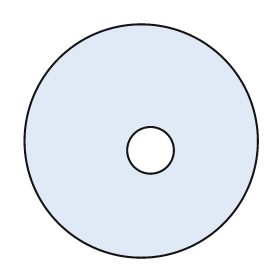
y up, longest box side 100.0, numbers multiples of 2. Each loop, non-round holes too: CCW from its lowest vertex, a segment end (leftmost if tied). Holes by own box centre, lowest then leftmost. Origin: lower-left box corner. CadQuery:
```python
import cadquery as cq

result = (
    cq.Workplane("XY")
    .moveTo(50.0, 50.0)
    .circle(50.0)
    .moveTo(54.0, 46.0)
    .circle(10.0)
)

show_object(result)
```